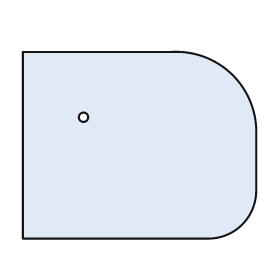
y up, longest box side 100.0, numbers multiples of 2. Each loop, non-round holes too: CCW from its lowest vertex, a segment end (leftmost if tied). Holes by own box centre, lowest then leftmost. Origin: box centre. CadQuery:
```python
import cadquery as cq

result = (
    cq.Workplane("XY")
    .moveTo(-50.0, -40.0)
    .lineTo(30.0, -40.0)
    .threePointArc((44.0, -34.0), (50.0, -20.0))
    .lineTo(50.0, 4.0)
    .threePointArc((40.0, 30.0), (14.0, 40.0))
    .lineTo(-50.0, 40.0)
    .close()
    .moveTo(-24.0, 12.0)
    .circle(2.0)
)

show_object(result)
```